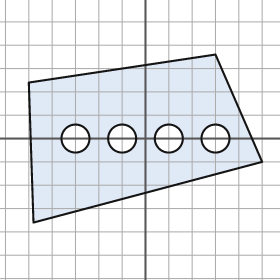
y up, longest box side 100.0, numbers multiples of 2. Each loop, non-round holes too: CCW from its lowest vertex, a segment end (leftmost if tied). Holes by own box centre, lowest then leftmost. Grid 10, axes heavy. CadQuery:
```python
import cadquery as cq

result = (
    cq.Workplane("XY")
    .moveTo(-48.0, -36.0)
    .lineTo(50.0, -10.0)
    .lineTo(30.0, 36.0)
    .lineTo(-50.0, 24.0)
    .close()
    .moveTo(-30.0, 0.0)
    .circle(6.0)
    .moveTo(-10.0, 0.0)
    .circle(6.0)
    .moveTo(10.0, 0.0)
    .circle(6.0)
    .moveTo(30.0, 0.0)
    .circle(6.0)
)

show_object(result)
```